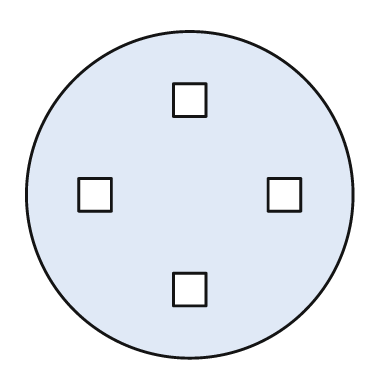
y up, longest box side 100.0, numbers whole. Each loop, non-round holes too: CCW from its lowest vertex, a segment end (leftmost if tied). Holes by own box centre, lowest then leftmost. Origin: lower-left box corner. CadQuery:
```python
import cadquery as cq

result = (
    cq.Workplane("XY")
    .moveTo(50.0, 50.0)
    .circle(50.0)
    .moveTo(45.0, 16.0)
    .lineTo(55.0, 16.0)
    .lineTo(55.0, 26.0)
    .lineTo(45.0, 26.0)
    .close()
    .moveTo(16.0, 45.0)
    .lineTo(26.0, 45.0)
    .lineTo(26.0, 55.0)
    .lineTo(16.0, 55.0)
    .close()
    .moveTo(74.0, 45.0)
    .lineTo(84.0, 45.0)
    .lineTo(84.0, 55.0)
    .lineTo(74.0, 55.0)
    .close()
    .moveTo(45.0, 74.0)
    .lineTo(55.0, 74.0)
    .lineTo(55.0, 84.0)
    .lineTo(45.0, 84.0)
    .close()
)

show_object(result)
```